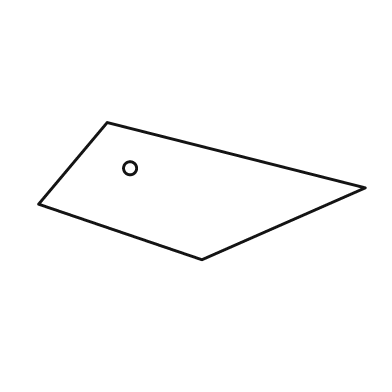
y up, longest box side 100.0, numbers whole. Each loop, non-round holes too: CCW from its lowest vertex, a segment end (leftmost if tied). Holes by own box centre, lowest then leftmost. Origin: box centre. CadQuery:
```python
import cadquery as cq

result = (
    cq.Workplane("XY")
    .moveTo(0.0, -21.0)
    .lineTo(50.0, 1.0)
    .lineTo(-29.0, 21.0)
    .lineTo(-50.0, -4.0)
    .close()
    .moveTo(-22.0, 7.0)
    .circle(2.0)
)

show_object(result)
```